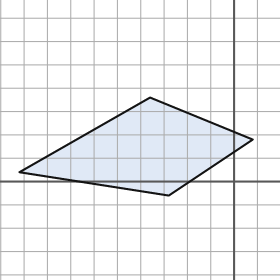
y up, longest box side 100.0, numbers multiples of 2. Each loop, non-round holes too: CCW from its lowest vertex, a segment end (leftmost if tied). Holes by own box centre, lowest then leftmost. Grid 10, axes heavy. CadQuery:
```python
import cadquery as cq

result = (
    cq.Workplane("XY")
    .moveTo(-28.0, -6.0)
    .lineTo(8.0, 18.0)
    .lineTo(-36.0, 36.0)
    .lineTo(-92.0, 4.0)
    .close()
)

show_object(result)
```